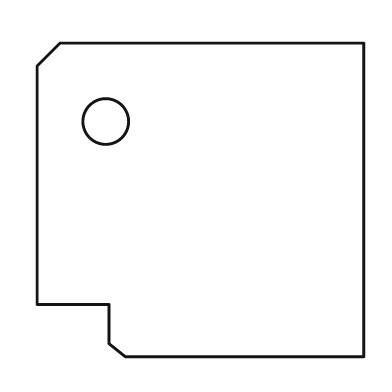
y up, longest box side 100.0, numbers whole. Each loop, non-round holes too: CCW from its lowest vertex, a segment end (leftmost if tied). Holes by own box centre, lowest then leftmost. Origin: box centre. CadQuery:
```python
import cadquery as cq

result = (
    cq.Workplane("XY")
    .moveTo(-23.0, -48.0)
    .lineTo(50.0, -48.0)
    .lineTo(50.0, 48.0)
    .lineTo(-43.0, 48.0)
    .lineTo(-50.0, 41.0)
    .lineTo(-50.0, -32.0)
    .lineTo(-28.0, -32.0)
    .lineTo(-28.0, -44.0)
    .close()
    .moveTo(-29.0, 24.0)
    .circle(7.0)
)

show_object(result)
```